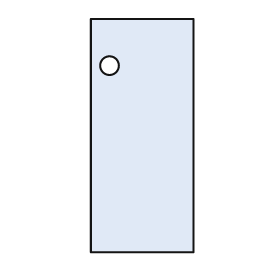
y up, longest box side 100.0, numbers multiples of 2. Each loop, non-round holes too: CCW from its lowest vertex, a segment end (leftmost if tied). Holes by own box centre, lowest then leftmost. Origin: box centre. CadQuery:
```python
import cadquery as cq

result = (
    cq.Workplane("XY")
    .moveTo(-22.0, -50.0)
    .lineTo(22.0, -50.0)
    .lineTo(22.0, 50.0)
    .lineTo(-22.0, 50.0)
    .close()
    .moveTo(-14.0, 30.0)
    .circle(4.0)
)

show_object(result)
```